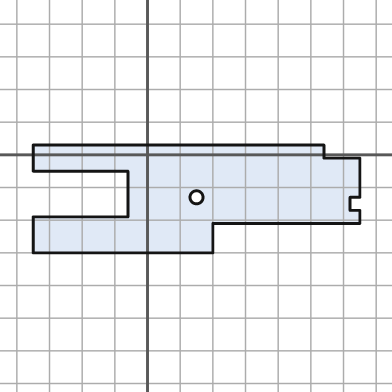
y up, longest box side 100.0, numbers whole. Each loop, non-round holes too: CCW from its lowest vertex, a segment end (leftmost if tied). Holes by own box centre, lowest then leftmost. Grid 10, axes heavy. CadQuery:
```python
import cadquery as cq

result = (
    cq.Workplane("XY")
    .moveTo(-35.0, -30.0)
    .lineTo(20.0, -30.0)
    .lineTo(20.0, -21.0)
    .lineTo(65.0, -21.0)
    .lineTo(65.0, -17.0)
    .lineTo(62.0, -17.0)
    .lineTo(62.0, -13.0)
    .lineTo(65.0, -13.0)
    .lineTo(65.0, -1.0)
    .lineTo(54.0, -1.0)
    .lineTo(54.0, 3.0)
    .lineTo(-35.0, 3.0)
    .lineTo(-35.0, -5.0)
    .lineTo(-6.0, -5.0)
    .lineTo(-6.0, -19.0)
    .lineTo(-35.0, -19.0)
    .close()
    .moveTo(15.0, -13.0)
    .circle(2.0)
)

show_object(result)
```